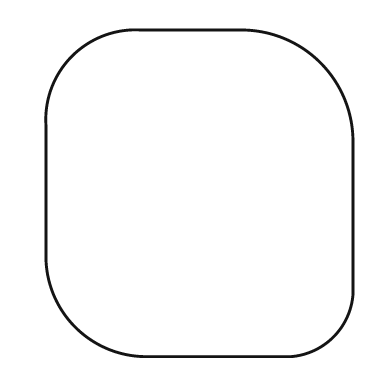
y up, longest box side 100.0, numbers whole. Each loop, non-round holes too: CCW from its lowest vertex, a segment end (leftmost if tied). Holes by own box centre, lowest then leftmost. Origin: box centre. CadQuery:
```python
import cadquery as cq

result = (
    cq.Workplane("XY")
    .moveTo(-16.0, -50.0)
    .lineTo(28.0, -50.0)
    .threePointArc((41.0, -44.0), (47.0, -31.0))
    .lineTo(47.0, 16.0)
    .threePointArc((37.0, 40.0), (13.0, 50.0))
    .lineTo(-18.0, 50.0)
    .threePointArc((-39.0, 42.0), (-47.0, 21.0))
    .lineTo(-47.0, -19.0)
    .threePointArc((-38.0, -41.0), (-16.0, -50.0))
    .close()
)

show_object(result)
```